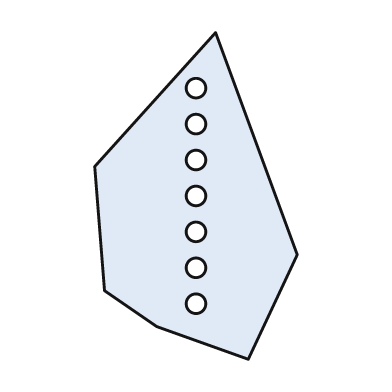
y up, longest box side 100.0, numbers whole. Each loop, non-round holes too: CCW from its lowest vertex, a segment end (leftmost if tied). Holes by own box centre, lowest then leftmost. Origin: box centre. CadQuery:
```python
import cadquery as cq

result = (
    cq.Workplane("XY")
    .moveTo(16.0, -50.0)
    .lineTo(31.0, -18.0)
    .lineTo(6.0, 50.0)
    .lineTo(-31.0, 9.0)
    .lineTo(-28.0, -29.0)
    .lineTo(-12.0, -40.0)
    .close()
    .moveTo(0.0, -33.0)
    .circle(3.0)
    .moveTo(0.0, -22.0)
    .circle(3.0)
    .moveTo(0.0, -11.0)
    .circle(3.0)
    .moveTo(0.0, 0.0)
    .circle(3.0)
    .moveTo(0.0, 11.0)
    .circle(3.0)
    .moveTo(0.0, 22.0)
    .circle(3.0)
    .moveTo(0.0, 33.0)
    .circle(3.0)
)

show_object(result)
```